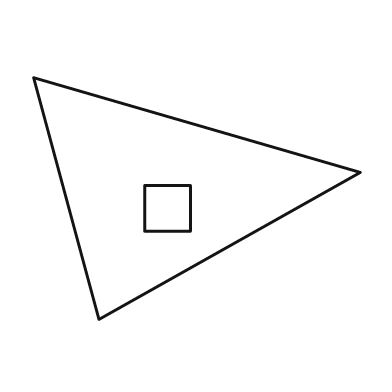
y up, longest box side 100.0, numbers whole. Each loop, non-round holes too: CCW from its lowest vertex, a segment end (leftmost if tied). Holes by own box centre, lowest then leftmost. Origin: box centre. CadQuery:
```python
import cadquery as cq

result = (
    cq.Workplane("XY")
    .moveTo(-30.0, -37.0)
    .lineTo(50.0, 8.0)
    .lineTo(-50.0, 37.0)
    .close()
    .moveTo(-16.0, -10.0)
    .lineTo(-2.0, -10.0)
    .lineTo(-2.0, 4.0)
    .lineTo(-16.0, 4.0)
    .close()
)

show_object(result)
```